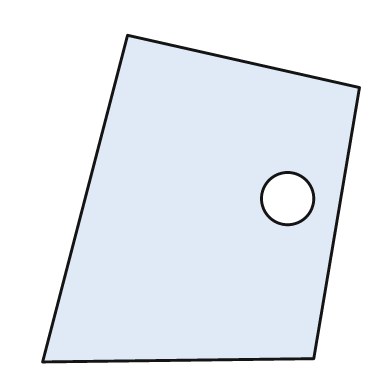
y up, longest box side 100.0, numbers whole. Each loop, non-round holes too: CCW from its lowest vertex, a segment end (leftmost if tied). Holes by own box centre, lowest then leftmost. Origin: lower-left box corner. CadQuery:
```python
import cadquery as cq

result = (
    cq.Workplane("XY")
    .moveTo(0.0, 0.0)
    .lineTo(83.0, 1.0)
    .lineTo(97.0, 84.0)
    .lineTo(26.0, 100.0)
    .close()
    .moveTo(75.0, 50.0)
    .circle(8.0)
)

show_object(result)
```